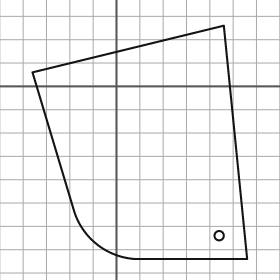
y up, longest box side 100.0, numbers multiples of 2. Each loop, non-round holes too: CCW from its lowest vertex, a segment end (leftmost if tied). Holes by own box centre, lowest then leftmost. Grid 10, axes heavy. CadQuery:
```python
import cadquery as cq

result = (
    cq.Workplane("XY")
    .moveTo(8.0, -74.0)
    .lineTo(56.0, -74.0)
    .lineTo(46.0, 26.0)
    .lineTo(-36.0, 6.0)
    .lineTo(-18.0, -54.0)
    .threePointArc((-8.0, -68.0), (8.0, -74.0))
    .close()
    .moveTo(44.0, -64.0)
    .circle(2.0)
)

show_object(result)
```